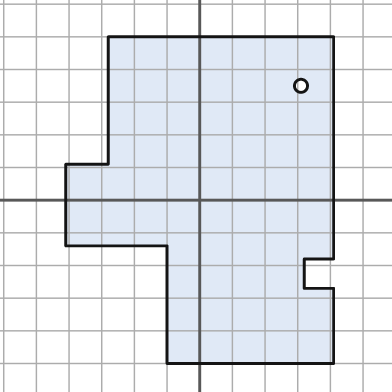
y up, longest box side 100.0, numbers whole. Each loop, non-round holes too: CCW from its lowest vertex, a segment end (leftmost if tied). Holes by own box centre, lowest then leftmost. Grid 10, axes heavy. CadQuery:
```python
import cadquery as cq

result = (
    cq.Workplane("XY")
    .moveTo(-10.0, -50.0)
    .lineTo(41.0, -50.0)
    .lineTo(41.0, -27.0)
    .lineTo(32.0, -27.0)
    .lineTo(32.0, -18.0)
    .lineTo(41.0, -18.0)
    .lineTo(41.0, 50.0)
    .lineTo(-28.0, 50.0)
    .lineTo(-28.0, 11.0)
    .lineTo(-41.0, 11.0)
    .lineTo(-41.0, -14.0)
    .lineTo(-10.0, -14.0)
    .close()
    .moveTo(31.0, 35.0)
    .circle(2.0)
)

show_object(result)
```